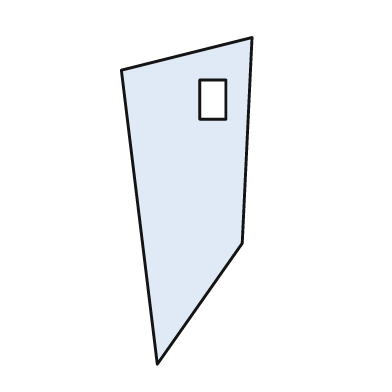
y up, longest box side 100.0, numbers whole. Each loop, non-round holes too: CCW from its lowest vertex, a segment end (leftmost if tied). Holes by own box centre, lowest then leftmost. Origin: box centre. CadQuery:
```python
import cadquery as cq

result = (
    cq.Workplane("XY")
    .moveTo(-9.0, -50.0)
    .lineTo(17.0, -13.0)
    .lineTo(20.0, 50.0)
    .lineTo(-20.0, 40.0)
    .close()
    .moveTo(4.0, 25.0)
    .lineTo(12.0, 25.0)
    .lineTo(12.0, 37.0)
    .lineTo(4.0, 37.0)
    .close()
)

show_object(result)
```